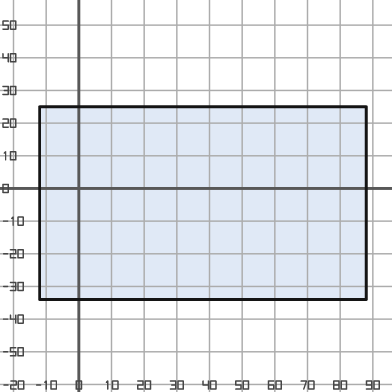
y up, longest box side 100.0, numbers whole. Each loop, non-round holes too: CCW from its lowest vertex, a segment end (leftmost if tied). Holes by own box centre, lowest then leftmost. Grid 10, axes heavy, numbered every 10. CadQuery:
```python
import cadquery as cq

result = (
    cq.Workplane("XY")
    .moveTo(-12.0, -34.0)
    .lineTo(88.0, -34.0)
    .lineTo(88.0, 25.0)
    .lineTo(-12.0, 25.0)
    .close()
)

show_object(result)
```